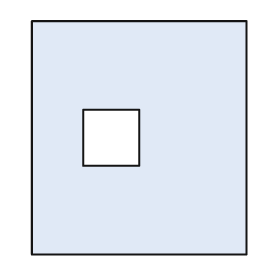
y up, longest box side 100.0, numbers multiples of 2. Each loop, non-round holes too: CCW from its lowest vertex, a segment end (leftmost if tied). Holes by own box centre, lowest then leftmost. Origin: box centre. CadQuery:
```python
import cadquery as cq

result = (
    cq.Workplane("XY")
    .moveTo(-46.0, -50.0)
    .lineTo(46.0, -50.0)
    .lineTo(46.0, 50.0)
    .lineTo(-46.0, 50.0)
    .close()
    .moveTo(-24.0, -12.0)
    .lineTo(0.0, -12.0)
    .lineTo(0.0, 12.0)
    .lineTo(-24.0, 12.0)
    .close()
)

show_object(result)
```